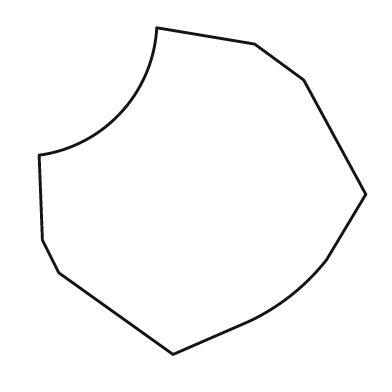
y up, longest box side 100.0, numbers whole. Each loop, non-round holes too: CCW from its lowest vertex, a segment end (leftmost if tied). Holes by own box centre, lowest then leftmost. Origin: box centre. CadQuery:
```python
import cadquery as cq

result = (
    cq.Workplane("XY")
    .moveTo(-9.0, -50.0)
    .lineTo(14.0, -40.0)
    .threePointArc((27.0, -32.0), (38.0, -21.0))
    .lineTo(50.0, -1.0)
    .lineTo(31.0, 34.0)
    .lineTo(16.0, 45.0)
    .lineTo(-14.0, 50.0)
    .threePointArc((-25.0, 24.0), (-50.0, 11.0))
    .lineTo(-49.0, -15.0)
    .lineTo(-44.0, -25.0)
    .close()
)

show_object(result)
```